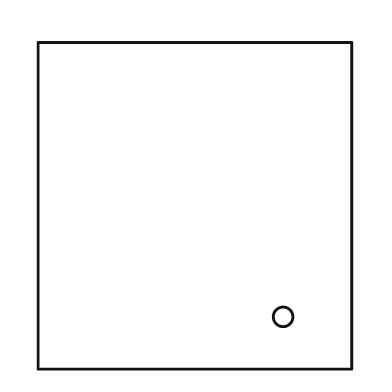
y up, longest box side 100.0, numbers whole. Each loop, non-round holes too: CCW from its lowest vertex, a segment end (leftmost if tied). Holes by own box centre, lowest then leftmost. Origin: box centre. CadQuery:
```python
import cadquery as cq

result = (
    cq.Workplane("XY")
    .moveTo(-48.0, -50.0)
    .lineTo(48.0, -50.0)
    .lineTo(48.0, 50.0)
    .lineTo(-48.0, 50.0)
    .close()
    .moveTo(27.0, -34.0)
    .circle(3.0)
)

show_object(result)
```